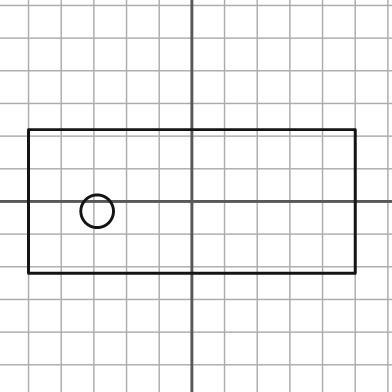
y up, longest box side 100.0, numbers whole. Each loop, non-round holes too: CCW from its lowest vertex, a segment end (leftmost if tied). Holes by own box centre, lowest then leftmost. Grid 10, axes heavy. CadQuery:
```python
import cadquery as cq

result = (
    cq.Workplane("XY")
    .moveTo(-50.0, -22.0)
    .lineTo(50.0, -22.0)
    .lineTo(50.0, 22.0)
    .lineTo(-50.0, 22.0)
    .close()
    .moveTo(-29.0, -3.0)
    .circle(5.0)
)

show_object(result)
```